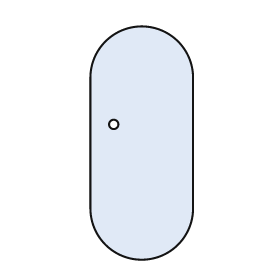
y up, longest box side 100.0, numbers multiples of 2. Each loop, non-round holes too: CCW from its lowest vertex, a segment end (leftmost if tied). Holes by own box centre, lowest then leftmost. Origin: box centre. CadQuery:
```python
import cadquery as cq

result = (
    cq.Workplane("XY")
    .moveTo(-22.0, -28.0)
    .threePointArc((0.0, -50.0), (22.0, -28.0))
    .lineTo(22.0, 28.0)
    .threePointArc((0.0, 50.0), (-22.0, 28.0))
    .close()
    .moveTo(-12.0, 8.0)
    .circle(2.0)
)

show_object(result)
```